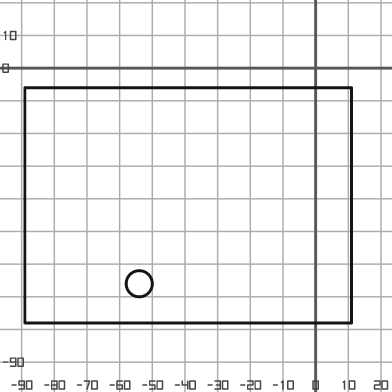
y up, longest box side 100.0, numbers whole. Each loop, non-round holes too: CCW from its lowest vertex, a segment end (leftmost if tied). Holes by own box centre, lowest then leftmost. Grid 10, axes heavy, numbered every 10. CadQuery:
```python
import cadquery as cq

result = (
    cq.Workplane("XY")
    .moveTo(-89.0, -78.0)
    .lineTo(11.0, -78.0)
    .lineTo(11.0, -6.0)
    .lineTo(-89.0, -6.0)
    .close()
    .moveTo(-54.0, -66.0)
    .circle(4.0)
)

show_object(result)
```